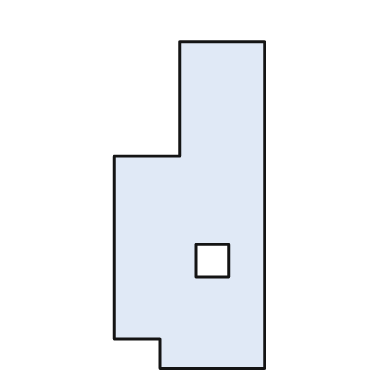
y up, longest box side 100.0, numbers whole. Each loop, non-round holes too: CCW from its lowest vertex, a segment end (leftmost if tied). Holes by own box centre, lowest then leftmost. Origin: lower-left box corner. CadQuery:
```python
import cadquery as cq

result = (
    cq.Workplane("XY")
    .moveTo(14.0, 0.0)
    .lineTo(46.0, 0.0)
    .lineTo(46.0, 100.0)
    .lineTo(20.0, 100.0)
    .lineTo(20.0, 65.0)
    .lineTo(0.0, 65.0)
    .lineTo(0.0, 9.0)
    .lineTo(14.0, 9.0)
    .close()
    .moveTo(25.0, 28.0)
    .lineTo(35.0, 28.0)
    .lineTo(35.0, 38.0)
    .lineTo(25.0, 38.0)
    .close()
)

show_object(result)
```